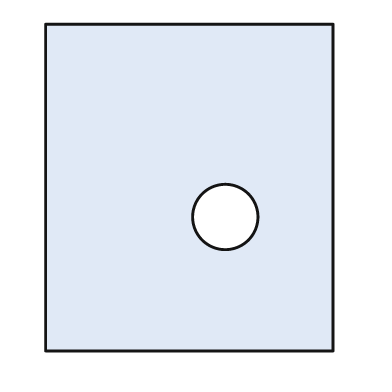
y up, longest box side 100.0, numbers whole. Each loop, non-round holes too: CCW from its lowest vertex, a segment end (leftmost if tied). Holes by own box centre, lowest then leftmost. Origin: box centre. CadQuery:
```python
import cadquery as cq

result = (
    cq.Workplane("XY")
    .moveTo(-44.0, -50.0)
    .lineTo(44.0, -50.0)
    .lineTo(44.0, 50.0)
    .lineTo(-44.0, 50.0)
    .close()
    .moveTo(11.0, -9.0)
    .circle(10.0)
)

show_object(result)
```